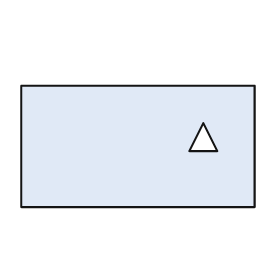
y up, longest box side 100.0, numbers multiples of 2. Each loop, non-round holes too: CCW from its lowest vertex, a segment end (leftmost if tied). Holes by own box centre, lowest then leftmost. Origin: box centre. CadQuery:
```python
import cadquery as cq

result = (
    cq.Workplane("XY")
    .moveTo(-50.0, -26.0)
    .lineTo(50.0, -26.0)
    .lineTo(50.0, 26.0)
    .lineTo(-50.0, 26.0)
    .close()
    .moveTo(22.0, -2.0)
    .lineTo(34.0, -2.0)
    .lineTo(28.0, 10.0)
    .close()
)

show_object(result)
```